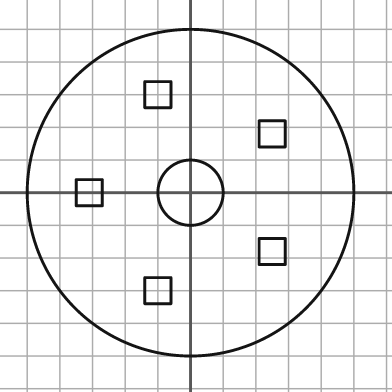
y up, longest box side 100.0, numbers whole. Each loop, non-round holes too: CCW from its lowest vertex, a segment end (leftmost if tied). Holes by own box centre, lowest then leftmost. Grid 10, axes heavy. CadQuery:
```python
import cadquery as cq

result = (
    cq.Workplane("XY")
    .moveTo(0.0, 0.0)
    .circle(50.0)
    .moveTo(-14.0, -34.0)
    .lineTo(-6.0, -34.0)
    .lineTo(-6.0, -26.0)
    .lineTo(-14.0, -26.0)
    .close()
    .moveTo(21.0, -22.0)
    .lineTo(29.0, -22.0)
    .lineTo(29.0, -14.0)
    .lineTo(21.0, -14.0)
    .close()
    .moveTo(-35.0, -4.0)
    .lineTo(-27.0, -4.0)
    .lineTo(-27.0, 4.0)
    .lineTo(-35.0, 4.0)
    .close()
    .moveTo(0.0, 0.0)
    .circle(10.0)
    .moveTo(21.0, 14.0)
    .lineTo(29.0, 14.0)
    .lineTo(29.0, 22.0)
    .lineTo(21.0, 22.0)
    .close()
    .moveTo(-14.0, 26.0)
    .lineTo(-6.0, 26.0)
    .lineTo(-6.0, 34.0)
    .lineTo(-14.0, 34.0)
    .close()
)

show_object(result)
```